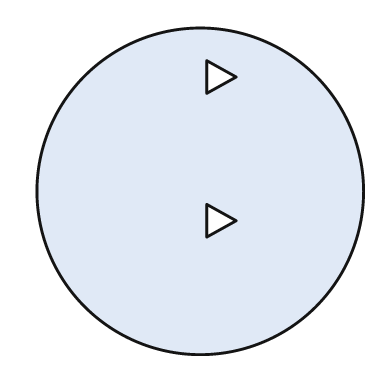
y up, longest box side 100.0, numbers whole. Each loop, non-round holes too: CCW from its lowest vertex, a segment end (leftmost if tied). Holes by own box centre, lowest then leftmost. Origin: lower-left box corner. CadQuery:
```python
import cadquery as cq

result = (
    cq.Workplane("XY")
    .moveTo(50.0, 50.0)
    .circle(50.0)
    .moveTo(52.0, 36.0)
    .lineTo(61.0, 41.0)
    .lineTo(52.0, 46.0)
    .close()
    .moveTo(52.0, 80.0)
    .lineTo(61.0, 85.0)
    .lineTo(52.0, 90.0)
    .close()
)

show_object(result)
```